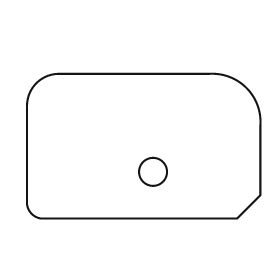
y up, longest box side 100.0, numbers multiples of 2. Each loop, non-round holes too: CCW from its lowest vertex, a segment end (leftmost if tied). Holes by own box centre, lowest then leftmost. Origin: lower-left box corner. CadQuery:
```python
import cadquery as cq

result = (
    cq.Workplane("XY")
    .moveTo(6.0, 0.0)
    .lineTo(90.0, 0.0)
    .lineTo(100.0, 10.0)
    .lineTo(100.0, 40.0)
    .threePointArc((94.0, 56.0), (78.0, 62.0))
    .lineTo(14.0, 62.0)
    .threePointArc((4.0, 58.0), (0.0, 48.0))
    .lineTo(0.0, 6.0)
    .threePointArc((2.0, 2.0), (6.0, 0.0))
    .close()
    .moveTo(54.0, 20.0)
    .circle(6.0)
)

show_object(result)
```